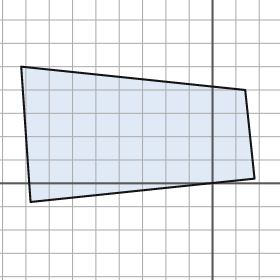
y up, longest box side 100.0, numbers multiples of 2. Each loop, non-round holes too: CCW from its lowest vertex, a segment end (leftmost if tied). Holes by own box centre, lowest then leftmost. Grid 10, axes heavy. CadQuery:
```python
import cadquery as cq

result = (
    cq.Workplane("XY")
    .moveTo(-78.0, -8.0)
    .lineTo(18.0, 2.0)
    .lineTo(14.0, 40.0)
    .lineTo(-82.0, 50.0)
    .close()
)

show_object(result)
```